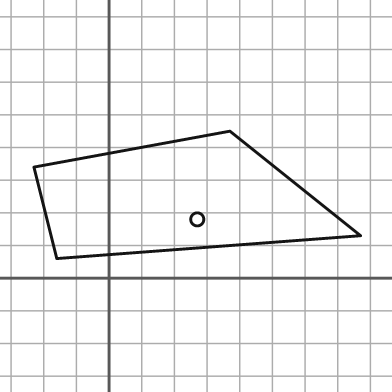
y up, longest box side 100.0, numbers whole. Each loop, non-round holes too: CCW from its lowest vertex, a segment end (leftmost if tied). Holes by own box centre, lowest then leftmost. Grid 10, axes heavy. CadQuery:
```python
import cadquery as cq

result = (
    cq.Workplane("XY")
    .moveTo(-16.0, 6.0)
    .lineTo(77.0, 13.0)
    .lineTo(37.0, 45.0)
    .lineTo(-23.0, 34.0)
    .close()
    .moveTo(27.0, 18.0)
    .circle(2.0)
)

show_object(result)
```